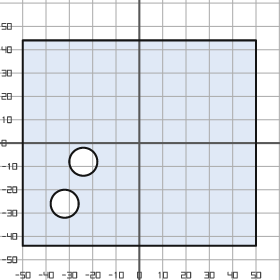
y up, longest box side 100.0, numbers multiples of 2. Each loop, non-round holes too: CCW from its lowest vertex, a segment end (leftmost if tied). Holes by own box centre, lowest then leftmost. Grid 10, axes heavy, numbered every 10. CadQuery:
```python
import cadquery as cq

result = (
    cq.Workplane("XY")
    .moveTo(-50.0, -44.0)
    .lineTo(50.0, -44.0)
    .lineTo(50.0, 44.0)
    .lineTo(-50.0, 44.0)
    .close()
    .moveTo(-32.0, -26.0)
    .circle(6.0)
    .moveTo(-24.0, -8.0)
    .circle(6.0)
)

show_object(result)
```